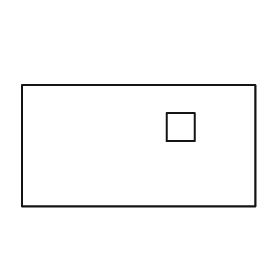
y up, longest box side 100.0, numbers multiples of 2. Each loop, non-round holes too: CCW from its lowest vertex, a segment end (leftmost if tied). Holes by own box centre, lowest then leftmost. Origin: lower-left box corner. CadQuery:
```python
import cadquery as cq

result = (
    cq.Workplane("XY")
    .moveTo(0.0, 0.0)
    .lineTo(100.0, 0.0)
    .lineTo(100.0, 52.0)
    .lineTo(0.0, 52.0)
    .close()
    .moveTo(62.0, 28.0)
    .lineTo(74.0, 28.0)
    .lineTo(74.0, 40.0)
    .lineTo(62.0, 40.0)
    .close()
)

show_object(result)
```